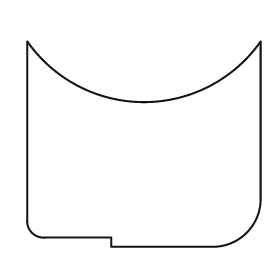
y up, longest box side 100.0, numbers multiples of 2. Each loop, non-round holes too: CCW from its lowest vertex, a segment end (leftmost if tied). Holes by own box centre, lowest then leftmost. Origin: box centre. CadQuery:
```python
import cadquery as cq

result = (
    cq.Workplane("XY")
    .moveTo(-14.0, -44.0)
    .lineTo(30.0, -44.0)
    .threePointArc((44.0, -38.0), (50.0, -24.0))
    .lineTo(50.0, 44.0)
    .threePointArc((0.0, 18.0), (-50.0, 44.0))
    .lineTo(-50.0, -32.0)
    .threePointArc((-48.0, -38.0), (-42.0, -40.0))
    .lineTo(-14.0, -40.0)
    .close()
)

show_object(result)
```